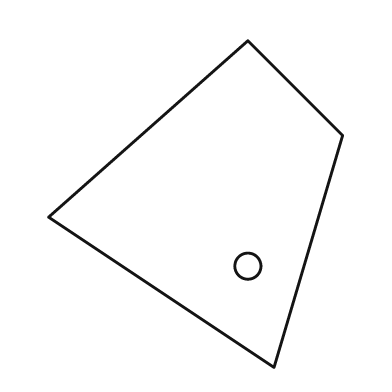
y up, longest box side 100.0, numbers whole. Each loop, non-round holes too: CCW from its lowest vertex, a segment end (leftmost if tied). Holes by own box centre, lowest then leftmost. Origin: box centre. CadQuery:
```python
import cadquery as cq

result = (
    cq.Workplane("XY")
    .moveTo(24.0, -50.0)
    .lineTo(45.0, 21.0)
    .lineTo(16.0, 50.0)
    .lineTo(-45.0, -4.0)
    .close()
    .moveTo(16.0, -19.0)
    .circle(4.0)
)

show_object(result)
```